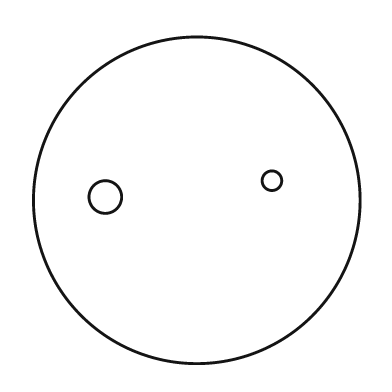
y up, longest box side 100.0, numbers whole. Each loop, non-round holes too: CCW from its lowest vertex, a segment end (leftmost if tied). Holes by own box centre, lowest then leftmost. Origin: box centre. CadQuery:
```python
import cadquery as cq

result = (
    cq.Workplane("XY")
    .moveTo(0.0, 0.0)
    .circle(50.0)
    .moveTo(-28.0, 1.0)
    .circle(5.0)
    .moveTo(23.0, 6.0)
    .circle(3.0)
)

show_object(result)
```